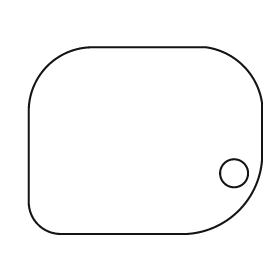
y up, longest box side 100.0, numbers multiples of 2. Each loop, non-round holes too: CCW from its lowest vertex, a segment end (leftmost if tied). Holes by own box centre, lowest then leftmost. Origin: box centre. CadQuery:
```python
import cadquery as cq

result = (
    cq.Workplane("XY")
    .moveTo(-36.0, -40.0)
    .lineTo(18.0, -40.0)
    .threePointArc((40.0, -30.0), (50.0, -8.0))
    .lineTo(50.0, 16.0)
    .threePointArc((42.0, 32.0), (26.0, 40.0))
    .lineTo(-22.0, 40.0)
    .threePointArc((-42.0, 32.0), (-50.0, 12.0))
    .lineTo(-50.0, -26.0)
    .threePointArc((-46.0, -36.0), (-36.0, -40.0))
    .close()
    .moveTo(38.0, -14.0)
    .circle(6.0)
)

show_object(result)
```